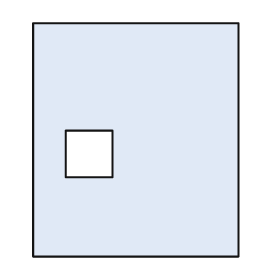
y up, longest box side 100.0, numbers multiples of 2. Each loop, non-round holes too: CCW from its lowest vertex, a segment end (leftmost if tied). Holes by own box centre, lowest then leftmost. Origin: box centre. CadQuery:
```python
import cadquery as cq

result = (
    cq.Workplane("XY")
    .moveTo(-44.0, -50.0)
    .lineTo(44.0, -50.0)
    .lineTo(44.0, 50.0)
    .lineTo(-44.0, 50.0)
    .close()
    .moveTo(-30.0, -16.0)
    .lineTo(-10.0, -16.0)
    .lineTo(-10.0, 4.0)
    .lineTo(-30.0, 4.0)
    .close()
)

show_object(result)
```